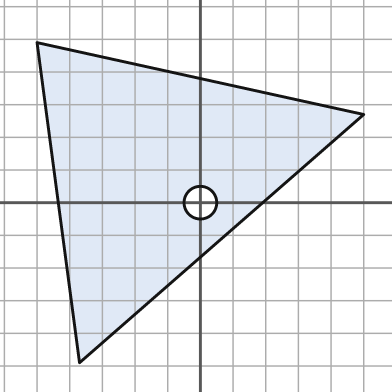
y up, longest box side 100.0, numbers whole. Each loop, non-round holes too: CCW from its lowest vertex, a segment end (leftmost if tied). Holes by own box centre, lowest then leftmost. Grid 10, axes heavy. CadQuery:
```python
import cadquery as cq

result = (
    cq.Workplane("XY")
    .moveTo(-37.0, -49.0)
    .lineTo(50.0, 27.0)
    .lineTo(-50.0, 49.0)
    .close()
    .moveTo(0.0, 0.0)
    .circle(5.0)
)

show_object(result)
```